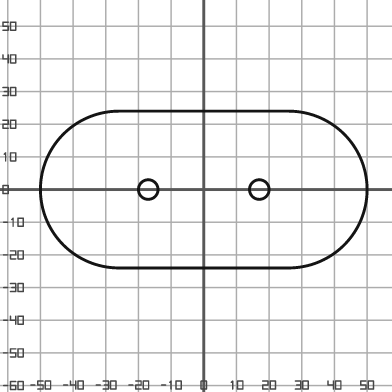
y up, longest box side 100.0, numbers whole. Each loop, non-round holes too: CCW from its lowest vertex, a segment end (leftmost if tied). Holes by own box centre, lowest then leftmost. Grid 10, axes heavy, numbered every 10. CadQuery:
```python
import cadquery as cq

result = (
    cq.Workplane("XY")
    .moveTo(-26.0, -24.0)
    .lineTo(26.0, -24.0)
    .threePointArc((50.0, 0.0), (26.0, 24.0))
    .lineTo(-26.0, 24.0)
    .threePointArc((-50.0, 0.0), (-26.0, -24.0))
    .close()
    .moveTo(-17.0, 0.0)
    .circle(3.0)
    .moveTo(17.0, 0.0)
    .circle(3.0)
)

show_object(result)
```